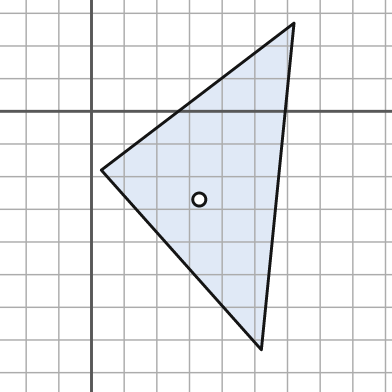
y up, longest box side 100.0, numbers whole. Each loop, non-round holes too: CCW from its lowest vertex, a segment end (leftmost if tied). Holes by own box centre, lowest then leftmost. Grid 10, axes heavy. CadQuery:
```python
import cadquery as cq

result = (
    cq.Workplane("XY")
    .moveTo(52.0, -73.0)
    .lineTo(62.0, 27.0)
    .lineTo(3.0, -18.0)
    .close()
    .moveTo(33.0, -27.0)
    .circle(2.0)
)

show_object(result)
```